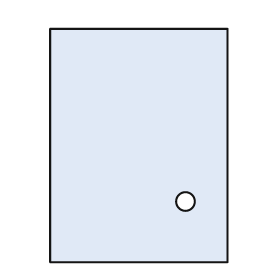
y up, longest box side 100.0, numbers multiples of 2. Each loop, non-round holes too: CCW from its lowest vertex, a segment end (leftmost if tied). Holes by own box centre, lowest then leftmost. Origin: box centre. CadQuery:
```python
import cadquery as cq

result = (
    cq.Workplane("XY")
    .moveTo(-38.0, -50.0)
    .lineTo(38.0, -50.0)
    .lineTo(38.0, 50.0)
    .lineTo(-38.0, 50.0)
    .close()
    .moveTo(20.0, -24.0)
    .circle(4.0)
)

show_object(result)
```